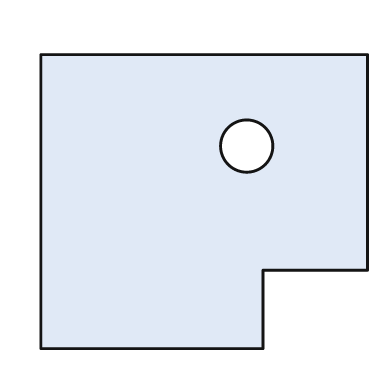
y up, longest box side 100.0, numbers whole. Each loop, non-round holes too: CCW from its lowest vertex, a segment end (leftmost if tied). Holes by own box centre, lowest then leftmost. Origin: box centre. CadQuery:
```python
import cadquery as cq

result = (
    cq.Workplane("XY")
    .moveTo(-50.0, -45.0)
    .lineTo(18.0, -45.0)
    .lineTo(18.0, -21.0)
    .lineTo(50.0, -21.0)
    .lineTo(50.0, 45.0)
    .lineTo(-50.0, 45.0)
    .close()
    .moveTo(13.0, 17.0)
    .circle(8.0)
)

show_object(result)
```